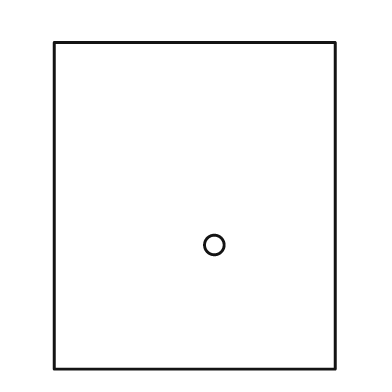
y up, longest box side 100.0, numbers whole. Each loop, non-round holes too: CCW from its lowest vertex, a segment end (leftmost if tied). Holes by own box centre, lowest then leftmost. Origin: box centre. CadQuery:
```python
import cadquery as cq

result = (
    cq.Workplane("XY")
    .moveTo(-43.0, -50.0)
    .lineTo(43.0, -50.0)
    .lineTo(43.0, 50.0)
    .lineTo(-43.0, 50.0)
    .close()
    .moveTo(6.0, -12.0)
    .circle(3.0)
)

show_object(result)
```